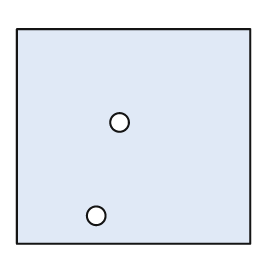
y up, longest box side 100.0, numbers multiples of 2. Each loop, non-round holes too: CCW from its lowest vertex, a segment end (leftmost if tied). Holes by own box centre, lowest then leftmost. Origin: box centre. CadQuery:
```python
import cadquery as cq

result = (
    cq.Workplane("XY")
    .moveTo(-50.0, -46.0)
    .lineTo(50.0, -46.0)
    .lineTo(50.0, 46.0)
    .lineTo(-50.0, 46.0)
    .close()
    .moveTo(-16.0, -34.0)
    .circle(4.0)
    .moveTo(-6.0, 6.0)
    .circle(4.0)
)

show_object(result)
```